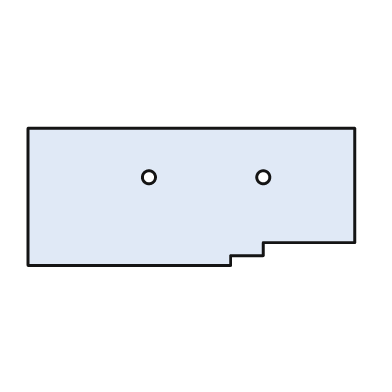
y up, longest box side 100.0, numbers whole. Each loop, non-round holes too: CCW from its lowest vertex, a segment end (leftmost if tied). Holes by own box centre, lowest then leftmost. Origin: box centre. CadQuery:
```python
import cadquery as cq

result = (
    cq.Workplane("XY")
    .moveTo(-50.0, -21.0)
    .lineTo(12.0, -21.0)
    .lineTo(12.0, -18.0)
    .lineTo(22.0, -18.0)
    .lineTo(22.0, -14.0)
    .lineTo(50.0, -14.0)
    .lineTo(50.0, 21.0)
    .lineTo(-50.0, 21.0)
    .close()
    .moveTo(-13.0, 6.0)
    .circle(2.0)
    .moveTo(22.0, 6.0)
    .circle(2.0)
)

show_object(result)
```